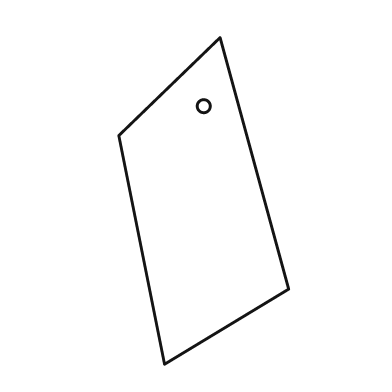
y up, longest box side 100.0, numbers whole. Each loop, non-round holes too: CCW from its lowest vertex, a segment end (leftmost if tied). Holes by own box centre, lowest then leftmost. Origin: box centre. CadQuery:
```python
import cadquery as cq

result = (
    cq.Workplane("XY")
    .moveTo(-12.0, -50.0)
    .lineTo(26.0, -27.0)
    .lineTo(5.0, 50.0)
    .lineTo(-26.0, 20.0)
    .close()
    .moveTo(0.0, 29.0)
    .circle(2.0)
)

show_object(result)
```